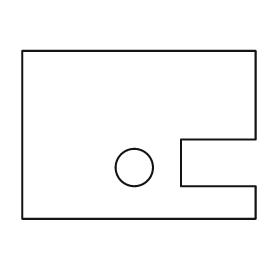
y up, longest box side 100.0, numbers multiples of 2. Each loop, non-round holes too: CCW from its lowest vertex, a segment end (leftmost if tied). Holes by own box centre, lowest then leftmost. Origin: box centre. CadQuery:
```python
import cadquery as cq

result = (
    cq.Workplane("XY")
    .moveTo(-50.0, -36.0)
    .lineTo(50.0, -36.0)
    .lineTo(50.0, -22.0)
    .lineTo(18.0, -22.0)
    .lineTo(18.0, -2.0)
    .lineTo(50.0, -2.0)
    .lineTo(50.0, 36.0)
    .lineTo(-50.0, 36.0)
    .close()
    .moveTo(-2.0, -14.0)
    .circle(8.0)
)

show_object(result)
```